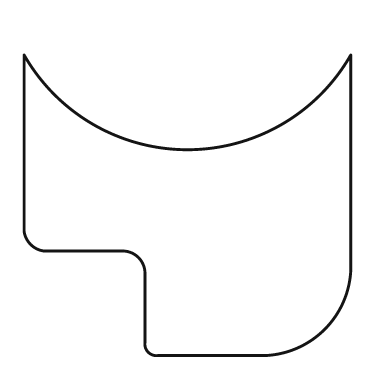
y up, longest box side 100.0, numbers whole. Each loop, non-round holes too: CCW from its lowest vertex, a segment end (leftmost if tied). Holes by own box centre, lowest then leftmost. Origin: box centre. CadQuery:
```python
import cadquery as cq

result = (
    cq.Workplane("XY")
    .moveTo(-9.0, -46.0)
    .lineTo(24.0, -46.0)
    .threePointArc((42.0, -38.0), (50.0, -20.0))
    .lineTo(50.0, 46.0)
    .threePointArc((0.0, 17.0), (-50.0, 46.0))
    .lineTo(-50.0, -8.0)
    .threePointArc((-48.0, -12.0), (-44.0, -14.0))
    .lineTo(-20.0, -14.0)
    .threePointArc((-15.0, -16.0), (-13.0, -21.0))
    .lineTo(-13.0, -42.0)
    .threePointArc((-12.0, -45.0), (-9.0, -46.0))
    .close()
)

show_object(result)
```